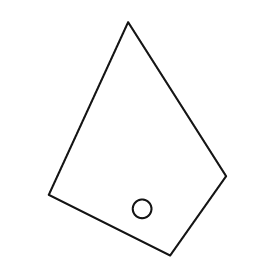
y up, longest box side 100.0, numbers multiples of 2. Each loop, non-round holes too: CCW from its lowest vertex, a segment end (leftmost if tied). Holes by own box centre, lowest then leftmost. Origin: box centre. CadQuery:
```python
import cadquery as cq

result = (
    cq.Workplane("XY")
    .moveTo(14.0, -50.0)
    .lineTo(38.0, -16.0)
    .lineTo(-4.0, 50.0)
    .lineTo(-38.0, -24.0)
    .close()
    .moveTo(2.0, -30.0)
    .circle(4.0)
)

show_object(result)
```